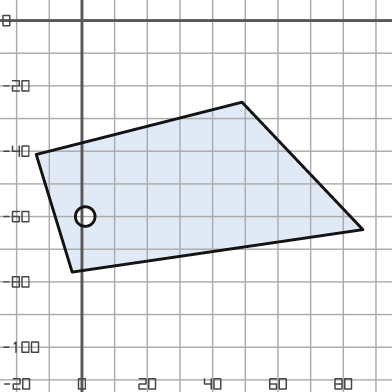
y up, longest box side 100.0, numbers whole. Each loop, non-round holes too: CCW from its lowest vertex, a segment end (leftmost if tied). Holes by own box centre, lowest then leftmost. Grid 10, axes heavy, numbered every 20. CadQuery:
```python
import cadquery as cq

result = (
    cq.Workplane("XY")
    .moveTo(-3.0, -77.0)
    .lineTo(86.0, -64.0)
    .lineTo(49.0, -25.0)
    .lineTo(-14.0, -41.0)
    .close()
    .moveTo(1.0, -60.0)
    .circle(3.0)
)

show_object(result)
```